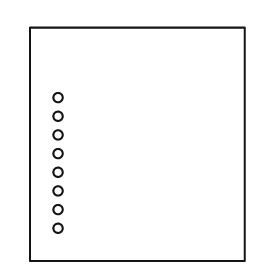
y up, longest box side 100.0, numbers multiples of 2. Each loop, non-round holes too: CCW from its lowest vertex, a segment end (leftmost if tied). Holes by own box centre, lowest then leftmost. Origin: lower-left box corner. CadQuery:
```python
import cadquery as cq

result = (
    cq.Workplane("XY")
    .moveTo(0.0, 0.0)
    .lineTo(92.0, 0.0)
    .lineTo(92.0, 100.0)
    .lineTo(0.0, 100.0)
    .close()
    .moveTo(12.0, 14.0)
    .circle(2.0)
    .moveTo(12.0, 22.0)
    .circle(2.0)
    .moveTo(12.0, 30.0)
    .circle(2.0)
    .moveTo(12.0, 38.0)
    .circle(2.0)
    .moveTo(12.0, 46.0)
    .circle(2.0)
    .moveTo(12.0, 54.0)
    .circle(2.0)
    .moveTo(12.0, 62.0)
    .circle(2.0)
    .moveTo(12.0, 70.0)
    .circle(2.0)
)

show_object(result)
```